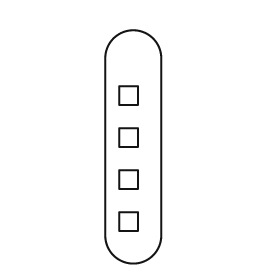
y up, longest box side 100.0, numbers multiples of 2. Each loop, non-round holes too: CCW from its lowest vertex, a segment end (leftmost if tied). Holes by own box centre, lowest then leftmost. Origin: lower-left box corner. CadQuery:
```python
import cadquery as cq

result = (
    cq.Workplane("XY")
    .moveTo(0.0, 12.0)
    .threePointArc((12.0, 0.0), (24.0, 12.0))
    .lineTo(24.0, 88.0)
    .threePointArc((12.0, 100.0), (0.0, 88.0))
    .close()
    .moveTo(6.0, 14.0)
    .lineTo(14.0, 14.0)
    .lineTo(14.0, 22.0)
    .lineTo(6.0, 22.0)
    .close()
    .moveTo(6.0, 32.0)
    .lineTo(14.0, 32.0)
    .lineTo(14.0, 40.0)
    .lineTo(6.0, 40.0)
    .close()
    .moveTo(6.0, 50.0)
    .lineTo(14.0, 50.0)
    .lineTo(14.0, 58.0)
    .lineTo(6.0, 58.0)
    .close()
    .moveTo(6.0, 68.0)
    .lineTo(14.0, 68.0)
    .lineTo(14.0, 76.0)
    .lineTo(6.0, 76.0)
    .close()
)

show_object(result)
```